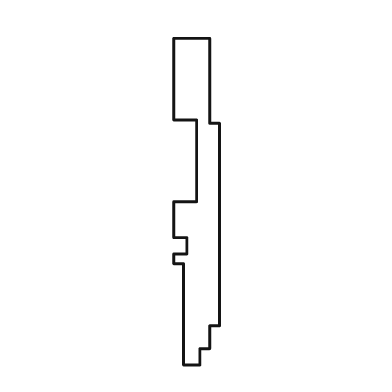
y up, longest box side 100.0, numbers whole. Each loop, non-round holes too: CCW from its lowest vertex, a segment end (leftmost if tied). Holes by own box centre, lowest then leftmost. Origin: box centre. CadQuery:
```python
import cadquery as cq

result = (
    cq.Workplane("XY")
    .moveTo(-4.0, -50.0)
    .lineTo(1.0, -50.0)
    .lineTo(1.0, -45.0)
    .lineTo(4.0, -45.0)
    .lineTo(4.0, -38.0)
    .lineTo(7.0, -38.0)
    .lineTo(7.0, 24.0)
    .lineTo(4.0, 24.0)
    .lineTo(4.0, 50.0)
    .lineTo(-7.0, 50.0)
    .lineTo(-7.0, 25.0)
    .lineTo(0.0, 25.0)
    .lineTo(0.0, 0.0)
    .lineTo(-7.0, 0.0)
    .lineTo(-7.0, -11.0)
    .lineTo(-3.0, -11.0)
    .lineTo(-3.0, -16.0)
    .lineTo(-7.0, -16.0)
    .lineTo(-7.0, -19.0)
    .lineTo(-4.0, -19.0)
    .close()
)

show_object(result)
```